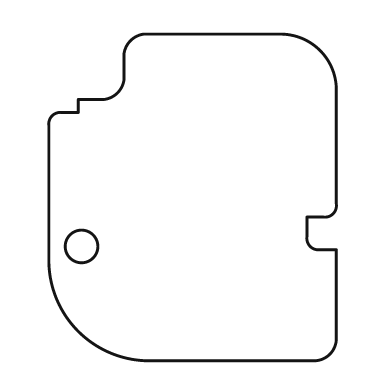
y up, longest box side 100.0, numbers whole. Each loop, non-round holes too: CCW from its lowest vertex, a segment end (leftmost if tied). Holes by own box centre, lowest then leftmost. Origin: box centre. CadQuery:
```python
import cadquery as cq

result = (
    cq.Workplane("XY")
    .moveTo(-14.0, -50.0)
    .lineTo(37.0, -50.0)
    .threePointArc((42.0, -48.0), (44.0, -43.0))
    .lineTo(44.0, -16.0)
    .lineTo(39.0, -16.0)
    .threePointArc((36.0, -15.0), (35.0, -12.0))
    .lineTo(35.0, -6.0)
    .lineTo(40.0, -6.0)
    .threePointArc((43.0, -5.0), (44.0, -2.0))
    .lineTo(44.0, 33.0)
    .threePointArc((39.0, 45.0), (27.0, 50.0))
    .lineTo(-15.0, 50.0)
    .threePointArc((-19.0, 48.0), (-21.0, 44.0))
    .lineTo(-21.0, 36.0)
    .threePointArc((-23.0, 32.0), (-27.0, 30.0))
    .lineTo(-35.0, 30.0)
    .lineTo(-35.0, 26.0)
    .lineTo(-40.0, 26.0)
    .threePointArc((-43.0, 25.0), (-44.0, 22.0))
    .lineTo(-44.0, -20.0)
    .threePointArc((-35.0, -41.0), (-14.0, -50.0))
    .close()
    .moveTo(-34.0, -15.0)
    .circle(5.0)
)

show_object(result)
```